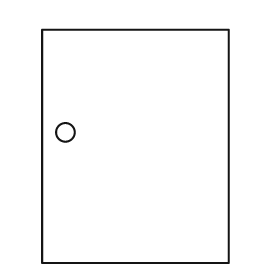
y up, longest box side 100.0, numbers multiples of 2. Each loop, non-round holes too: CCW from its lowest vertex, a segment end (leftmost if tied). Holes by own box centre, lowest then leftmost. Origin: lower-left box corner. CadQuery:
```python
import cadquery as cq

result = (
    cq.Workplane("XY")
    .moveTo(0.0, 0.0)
    .lineTo(80.0, 0.0)
    .lineTo(80.0, 100.0)
    .lineTo(0.0, 100.0)
    .close()
    .moveTo(10.0, 56.0)
    .circle(4.0)
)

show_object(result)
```